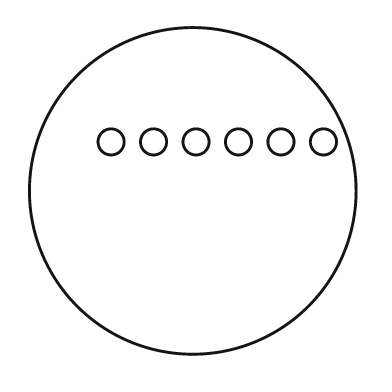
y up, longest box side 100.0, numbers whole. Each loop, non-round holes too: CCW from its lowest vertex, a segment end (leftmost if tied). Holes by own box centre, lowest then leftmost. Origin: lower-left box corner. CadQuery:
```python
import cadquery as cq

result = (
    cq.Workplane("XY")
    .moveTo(50.0, 50.0)
    .circle(50.0)
    .moveTo(25.0, 65.0)
    .circle(4.0)
    .moveTo(38.0, 65.0)
    .circle(4.0)
    .moveTo(51.0, 65.0)
    .circle(4.0)
    .moveTo(64.0, 65.0)
    .circle(4.0)
    .moveTo(77.0, 65.0)
    .circle(4.0)
    .moveTo(90.0, 65.0)
    .circle(4.0)
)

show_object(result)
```